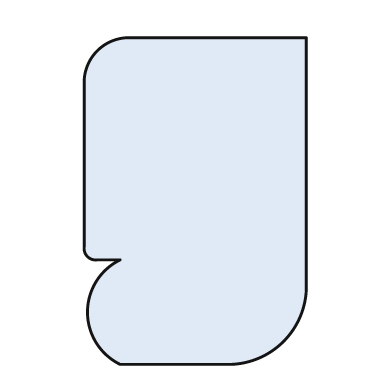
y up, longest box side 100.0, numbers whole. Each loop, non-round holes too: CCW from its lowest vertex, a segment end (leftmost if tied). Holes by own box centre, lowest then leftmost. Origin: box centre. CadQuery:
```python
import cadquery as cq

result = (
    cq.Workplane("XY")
    .moveTo(-23.0, -50.0)
    .lineTo(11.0, -50.0)
    .threePointArc((27.0, -43.0), (34.0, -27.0))
    .lineTo(34.0, 50.0)
    .lineTo(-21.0, 50.0)
    .threePointArc((-30.0, 46.0), (-34.0, 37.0))
    .lineTo(-34.0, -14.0)
    .threePointArc((-33.0, -17.0), (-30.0, -18.0))
    .lineTo(-23.0, -18.0)
    .threePointArc((-33.0, -34.0), (-23.0, -50.0))
    .close()
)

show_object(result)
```